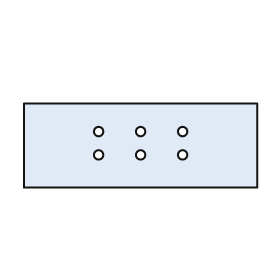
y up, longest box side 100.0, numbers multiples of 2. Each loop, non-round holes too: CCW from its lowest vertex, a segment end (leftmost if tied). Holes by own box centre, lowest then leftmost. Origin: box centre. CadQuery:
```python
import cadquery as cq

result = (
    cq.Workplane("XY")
    .moveTo(-50.0, -18.0)
    .lineTo(50.0, -18.0)
    .lineTo(50.0, 18.0)
    .lineTo(-50.0, 18.0)
    .close()
    .moveTo(-18.0, -4.0)
    .circle(2.0)
    .moveTo(0.0, -4.0)
    .circle(2.0)
    .moveTo(18.0, -4.0)
    .circle(2.0)
    .moveTo(-18.0, 6.0)
    .circle(2.0)
    .moveTo(0.0, 6.0)
    .circle(2.0)
    .moveTo(18.0, 6.0)
    .circle(2.0)
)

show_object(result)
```